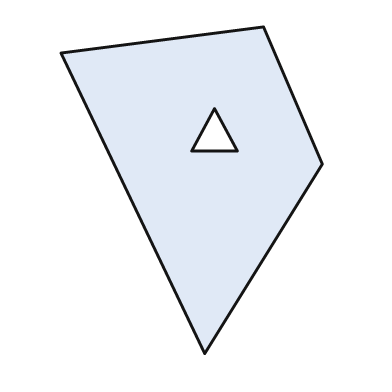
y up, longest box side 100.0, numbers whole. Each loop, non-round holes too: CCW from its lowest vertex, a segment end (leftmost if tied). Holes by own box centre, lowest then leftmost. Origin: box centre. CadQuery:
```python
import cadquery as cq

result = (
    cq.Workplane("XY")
    .moveTo(4.0, -50.0)
    .lineTo(40.0, 8.0)
    .lineTo(22.0, 50.0)
    .lineTo(-40.0, 42.0)
    .close()
    .moveTo(0.0, 12.0)
    .lineTo(14.0, 12.0)
    .lineTo(7.0, 25.0)
    .close()
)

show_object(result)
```